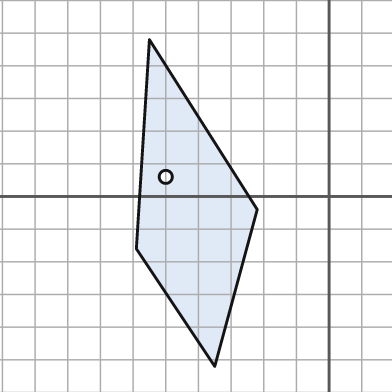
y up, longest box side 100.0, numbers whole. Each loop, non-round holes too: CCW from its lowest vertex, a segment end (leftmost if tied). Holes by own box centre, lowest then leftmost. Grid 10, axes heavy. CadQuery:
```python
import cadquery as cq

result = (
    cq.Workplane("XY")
    .moveTo(-35.0, -52.0)
    .lineTo(-22.0, -4.0)
    .lineTo(-55.0, 48.0)
    .lineTo(-59.0, -16.0)
    .close()
    .moveTo(-50.0, 6.0)
    .circle(2.0)
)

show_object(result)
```